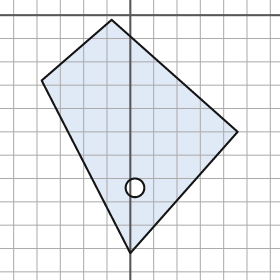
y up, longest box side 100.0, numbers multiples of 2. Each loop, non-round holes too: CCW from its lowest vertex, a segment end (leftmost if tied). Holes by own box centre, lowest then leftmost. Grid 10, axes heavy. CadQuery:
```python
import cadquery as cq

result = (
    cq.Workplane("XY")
    .moveTo(0.0, -102.0)
    .lineTo(46.0, -50.0)
    .lineTo(-8.0, -2.0)
    .lineTo(-38.0, -28.0)
    .close()
    .moveTo(2.0, -74.0)
    .circle(4.0)
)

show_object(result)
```